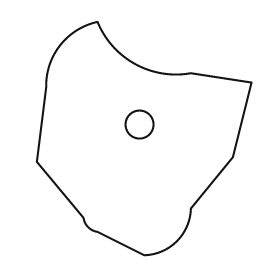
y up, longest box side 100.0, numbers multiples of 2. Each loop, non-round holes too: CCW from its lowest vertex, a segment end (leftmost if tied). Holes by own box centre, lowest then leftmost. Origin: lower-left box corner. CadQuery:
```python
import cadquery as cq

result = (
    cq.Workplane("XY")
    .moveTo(46.0, 0.0)
    .threePointArc((60.0, 6.0), (66.0, 20.0))
    .lineTo(84.0, 42.0)
    .lineTo(92.0, 74.0)
    .lineTo(66.0, 78.0)
    .threePointArc((42.0, 82.0), (26.0, 100.0))
    .threePointArc((10.0, 90.0), (4.0, 72.0))
    .lineTo(0.0, 40.0)
    .lineTo(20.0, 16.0)
    .threePointArc((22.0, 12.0), (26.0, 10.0))
    .close()
    .moveTo(44.0, 56.0)
    .circle(6.0)
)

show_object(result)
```